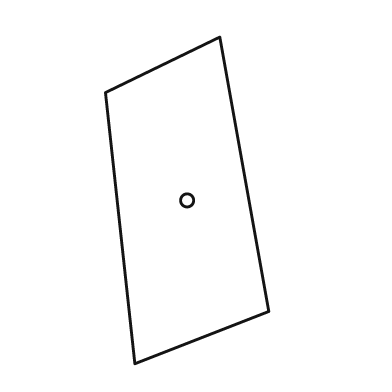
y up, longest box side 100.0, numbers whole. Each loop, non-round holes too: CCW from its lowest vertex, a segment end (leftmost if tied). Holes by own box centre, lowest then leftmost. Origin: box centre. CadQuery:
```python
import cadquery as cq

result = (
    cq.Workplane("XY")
    .moveTo(-16.0, -50.0)
    .lineTo(25.0, -34.0)
    .lineTo(10.0, 50.0)
    .lineTo(-25.0, 33.0)
    .close()
    .moveTo(0.0, 0.0)
    .circle(2.0)
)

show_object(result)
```